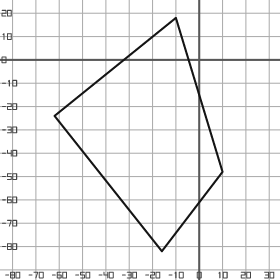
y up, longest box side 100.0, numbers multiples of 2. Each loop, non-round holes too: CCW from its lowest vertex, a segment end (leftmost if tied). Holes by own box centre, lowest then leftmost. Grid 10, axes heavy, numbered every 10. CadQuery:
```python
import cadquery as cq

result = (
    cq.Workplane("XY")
    .moveTo(-16.0, -82.0)
    .lineTo(10.0, -48.0)
    .lineTo(-10.0, 18.0)
    .lineTo(-62.0, -24.0)
    .close()
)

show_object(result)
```